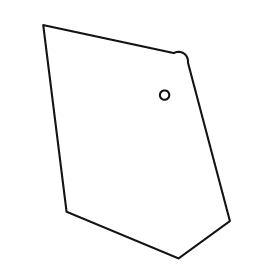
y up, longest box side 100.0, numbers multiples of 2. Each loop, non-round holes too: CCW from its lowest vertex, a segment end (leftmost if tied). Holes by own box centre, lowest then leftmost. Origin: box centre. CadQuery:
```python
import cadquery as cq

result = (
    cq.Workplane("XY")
    .moveTo(18.0, -50.0)
    .lineTo(40.0, -34.0)
    .lineTo(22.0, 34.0)
    .threePointArc((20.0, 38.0), (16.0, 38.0))
    .lineTo(-40.0, 50.0)
    .lineTo(-30.0, -30.0)
    .close()
    .moveTo(12.0, 20.0)
    .circle(2.0)
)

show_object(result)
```